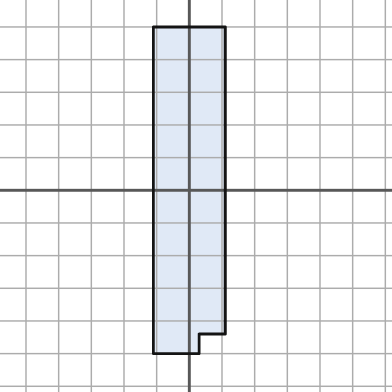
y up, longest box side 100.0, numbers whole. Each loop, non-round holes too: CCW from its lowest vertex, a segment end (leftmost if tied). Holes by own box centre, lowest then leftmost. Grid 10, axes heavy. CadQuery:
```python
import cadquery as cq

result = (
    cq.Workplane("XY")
    .moveTo(-11.0, -50.0)
    .lineTo(3.0, -50.0)
    .lineTo(3.0, -44.0)
    .lineTo(11.0, -44.0)
    .lineTo(11.0, 50.0)
    .lineTo(-11.0, 50.0)
    .close()
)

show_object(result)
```